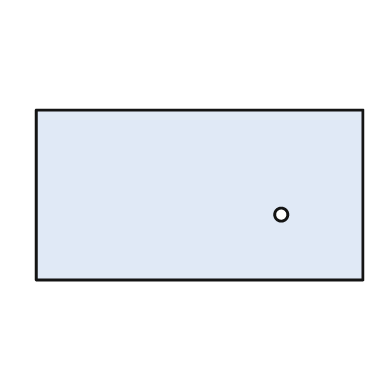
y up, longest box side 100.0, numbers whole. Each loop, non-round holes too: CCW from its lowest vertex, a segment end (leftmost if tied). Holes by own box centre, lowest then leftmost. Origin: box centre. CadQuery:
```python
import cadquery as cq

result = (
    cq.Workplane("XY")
    .moveTo(-50.0, -26.0)
    .lineTo(50.0, -26.0)
    .lineTo(50.0, 26.0)
    .lineTo(-50.0, 26.0)
    .close()
    .moveTo(25.0, -6.0)
    .circle(2.0)
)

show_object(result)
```